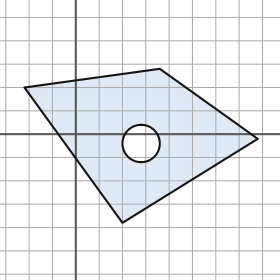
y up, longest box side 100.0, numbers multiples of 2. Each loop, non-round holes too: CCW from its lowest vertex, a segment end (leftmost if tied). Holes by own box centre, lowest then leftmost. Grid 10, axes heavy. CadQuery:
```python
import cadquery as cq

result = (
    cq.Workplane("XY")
    .moveTo(20.0, -38.0)
    .lineTo(78.0, -2.0)
    .lineTo(36.0, 28.0)
    .lineTo(-22.0, 20.0)
    .close()
    .moveTo(28.0, -4.0)
    .circle(8.0)
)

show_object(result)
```